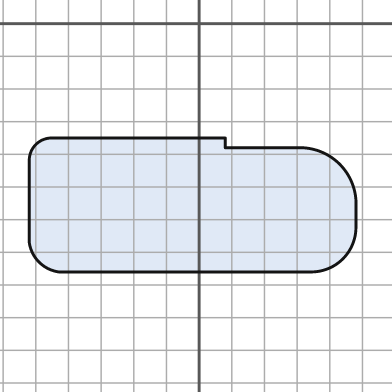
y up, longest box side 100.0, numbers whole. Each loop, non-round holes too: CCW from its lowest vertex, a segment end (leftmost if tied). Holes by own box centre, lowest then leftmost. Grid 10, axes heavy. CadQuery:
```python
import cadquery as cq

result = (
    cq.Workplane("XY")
    .moveTo(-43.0, -76.0)
    .lineTo(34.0, -76.0)
    .threePointArc((44.0, -72.0), (48.0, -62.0))
    .lineTo(48.0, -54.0)
    .threePointArc((43.0, -43.0), (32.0, -38.0))
    .lineTo(8.0, -38.0)
    .lineTo(8.0, -35.0)
    .lineTo(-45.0, -35.0)
    .threePointArc((-50.0, -37.0), (-52.0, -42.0))
    .lineTo(-52.0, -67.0)
    .threePointArc((-49.0, -73.0), (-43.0, -76.0))
    .close()
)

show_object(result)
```